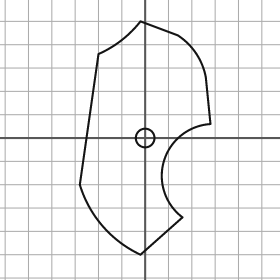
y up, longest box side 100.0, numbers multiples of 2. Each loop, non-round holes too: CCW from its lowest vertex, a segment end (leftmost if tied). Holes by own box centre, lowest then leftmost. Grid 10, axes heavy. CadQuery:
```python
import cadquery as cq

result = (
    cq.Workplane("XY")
    .moveTo(-2.0, -50.0)
    .lineTo(16.0, -34.0)
    .threePointArc((8.0, -10.0), (28.0, 6.0))
    .lineTo(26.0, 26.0)
    .threePointArc((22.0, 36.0), (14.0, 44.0))
    .lineTo(-2.0, 50.0)
    .threePointArc((-10.0, 42.0), (-20.0, 36.0))
    .lineTo(-28.0, -20.0)
    .threePointArc((-18.0, -38.0), (-2.0, -50.0))
    .close()
    .moveTo(0.0, 0.0)
    .circle(4.0)
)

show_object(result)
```